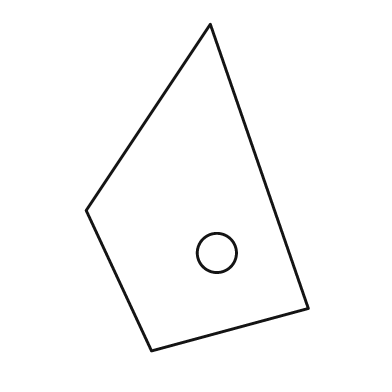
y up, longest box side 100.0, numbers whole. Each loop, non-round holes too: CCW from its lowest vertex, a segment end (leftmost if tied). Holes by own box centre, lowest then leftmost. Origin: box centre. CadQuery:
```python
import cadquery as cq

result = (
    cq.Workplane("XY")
    .moveTo(-14.0, -50.0)
    .lineTo(34.0, -37.0)
    .lineTo(4.0, 50.0)
    .lineTo(-34.0, -7.0)
    .close()
    .moveTo(6.0, -20.0)
    .circle(6.0)
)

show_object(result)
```